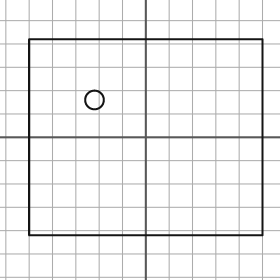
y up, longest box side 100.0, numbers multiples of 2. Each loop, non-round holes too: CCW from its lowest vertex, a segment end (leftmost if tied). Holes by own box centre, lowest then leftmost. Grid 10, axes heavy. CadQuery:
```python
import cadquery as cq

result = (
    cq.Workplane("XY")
    .moveTo(-50.0, -42.0)
    .lineTo(50.0, -42.0)
    .lineTo(50.0, 42.0)
    .lineTo(-50.0, 42.0)
    .close()
    .moveTo(-22.0, 16.0)
    .circle(4.0)
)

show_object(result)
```